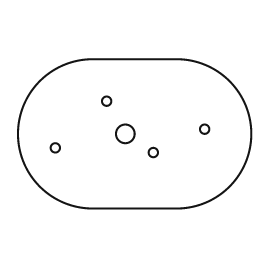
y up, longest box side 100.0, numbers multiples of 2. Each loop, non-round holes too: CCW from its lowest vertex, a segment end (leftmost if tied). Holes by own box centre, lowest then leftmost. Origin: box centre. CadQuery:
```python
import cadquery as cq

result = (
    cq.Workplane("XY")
    .moveTo(-18.0, -32.0)
    .lineTo(18.0, -32.0)
    .threePointArc((50.0, 0.0), (18.0, 32.0))
    .lineTo(-18.0, 32.0)
    .threePointArc((-50.0, 0.0), (-18.0, -32.0))
    .close()
    .moveTo(8.0, -8.0)
    .circle(2.0)
    .moveTo(-34.0, -6.0)
    .circle(2.0)
    .moveTo(-4.0, 0.0)
    .circle(4.0)
    .moveTo(30.0, 2.0)
    .circle(2.0)
    .moveTo(-12.0, 14.0)
    .circle(2.0)
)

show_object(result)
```